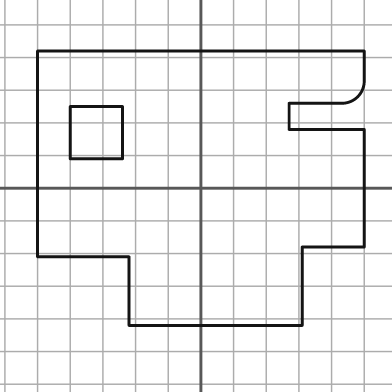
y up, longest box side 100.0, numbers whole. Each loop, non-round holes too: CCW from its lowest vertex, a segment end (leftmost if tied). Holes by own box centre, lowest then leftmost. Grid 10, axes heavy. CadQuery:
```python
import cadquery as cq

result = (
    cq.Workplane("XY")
    .moveTo(-22.0, -42.0)
    .lineTo(31.0, -42.0)
    .lineTo(31.0, -18.0)
    .lineTo(50.0, -18.0)
    .lineTo(50.0, 18.0)
    .lineTo(27.0, 18.0)
    .lineTo(27.0, 26.0)
    .lineTo(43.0, 26.0)
    .threePointArc((48.0, 28.0), (50.0, 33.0))
    .lineTo(50.0, 42.0)
    .lineTo(-50.0, 42.0)
    .lineTo(-50.0, -21.0)
    .lineTo(-22.0, -21.0)
    .close()
    .moveTo(-40.0, 9.0)
    .lineTo(-24.0, 9.0)
    .lineTo(-24.0, 25.0)
    .lineTo(-40.0, 25.0)
    .close()
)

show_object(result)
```